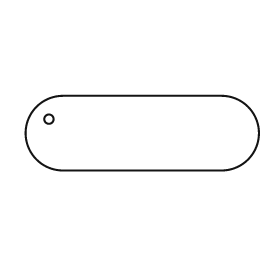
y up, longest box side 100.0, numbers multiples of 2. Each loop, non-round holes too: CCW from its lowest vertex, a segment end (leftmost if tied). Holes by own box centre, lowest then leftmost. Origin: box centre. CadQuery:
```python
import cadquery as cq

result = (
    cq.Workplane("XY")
    .moveTo(-34.0, -16.0)
    .lineTo(34.0, -16.0)
    .threePointArc((50.0, 0.0), (34.0, 16.0))
    .lineTo(-34.0, 16.0)
    .threePointArc((-50.0, 0.0), (-34.0, -16.0))
    .close()
    .moveTo(-40.0, 6.0)
    .circle(2.0)
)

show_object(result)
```